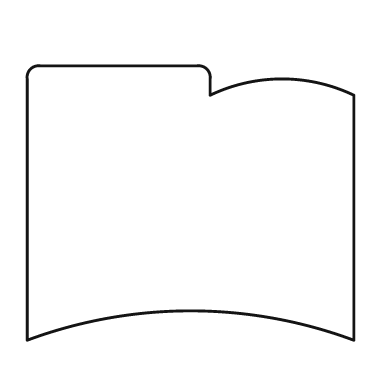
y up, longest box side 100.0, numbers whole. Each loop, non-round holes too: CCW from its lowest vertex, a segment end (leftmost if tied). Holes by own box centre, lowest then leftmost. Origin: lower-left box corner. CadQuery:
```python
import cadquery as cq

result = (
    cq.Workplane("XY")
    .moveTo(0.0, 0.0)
    .threePointArc((50.0, 9.0), (100.0, 0.0))
    .lineTo(100.0, 75.0)
    .threePointArc((78.0, 80.0), (56.0, 75.0))
    .lineTo(56.0, 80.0)
    .threePointArc((55.0, 83.0), (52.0, 84.0))
    .lineTo(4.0, 84.0)
    .threePointArc((1.0, 83.0), (0.0, 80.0))
    .close()
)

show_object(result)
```